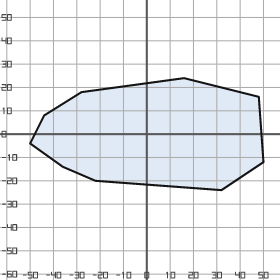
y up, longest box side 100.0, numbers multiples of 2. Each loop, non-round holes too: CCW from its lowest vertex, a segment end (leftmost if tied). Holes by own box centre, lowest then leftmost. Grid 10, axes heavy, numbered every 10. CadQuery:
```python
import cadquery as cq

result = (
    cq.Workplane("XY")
    .moveTo(32.0, -24.0)
    .lineTo(50.0, -12.0)
    .lineTo(48.0, 16.0)
    .lineTo(16.0, 24.0)
    .lineTo(-28.0, 18.0)
    .lineTo(-44.0, 8.0)
    .lineTo(-50.0, -4.0)
    .lineTo(-36.0, -14.0)
    .lineTo(-22.0, -20.0)
    .close()
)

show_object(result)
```